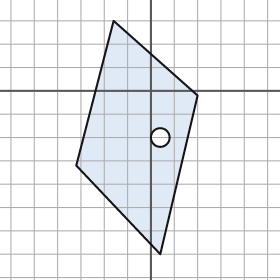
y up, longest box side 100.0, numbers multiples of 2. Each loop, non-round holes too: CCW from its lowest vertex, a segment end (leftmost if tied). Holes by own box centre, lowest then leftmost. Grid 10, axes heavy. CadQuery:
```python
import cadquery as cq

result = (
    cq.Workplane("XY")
    .moveTo(4.0, -70.0)
    .lineTo(20.0, -2.0)
    .lineTo(-16.0, 30.0)
    .lineTo(-32.0, -32.0)
    .close()
    .moveTo(4.0, -20.0)
    .circle(4.0)
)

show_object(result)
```